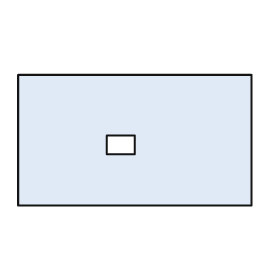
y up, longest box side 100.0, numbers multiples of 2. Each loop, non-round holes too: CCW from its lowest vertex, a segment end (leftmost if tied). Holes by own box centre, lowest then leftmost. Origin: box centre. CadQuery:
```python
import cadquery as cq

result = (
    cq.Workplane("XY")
    .moveTo(-50.0, -28.0)
    .lineTo(50.0, -28.0)
    .lineTo(50.0, 28.0)
    .lineTo(-50.0, 28.0)
    .close()
    .moveTo(-12.0, -6.0)
    .lineTo(0.0, -6.0)
    .lineTo(0.0, 2.0)
    .lineTo(-12.0, 2.0)
    .close()
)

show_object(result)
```